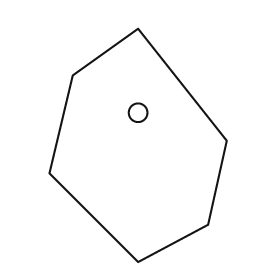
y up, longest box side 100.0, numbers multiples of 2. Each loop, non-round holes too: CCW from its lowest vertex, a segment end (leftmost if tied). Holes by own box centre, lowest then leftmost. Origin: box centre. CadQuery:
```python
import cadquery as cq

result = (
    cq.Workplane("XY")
    .moveTo(0.0, -50.0)
    .lineTo(30.0, -34.0)
    .lineTo(38.0, 2.0)
    .lineTo(0.0, 50.0)
    .lineTo(-28.0, 30.0)
    .lineTo(-38.0, -12.0)
    .close()
    .moveTo(0.0, 14.0)
    .circle(4.0)
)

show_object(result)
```